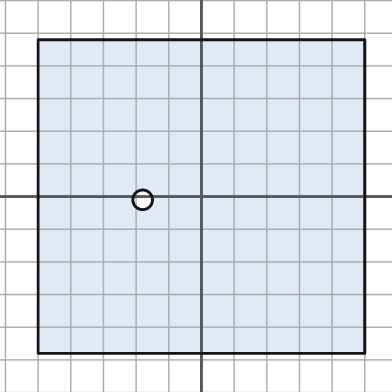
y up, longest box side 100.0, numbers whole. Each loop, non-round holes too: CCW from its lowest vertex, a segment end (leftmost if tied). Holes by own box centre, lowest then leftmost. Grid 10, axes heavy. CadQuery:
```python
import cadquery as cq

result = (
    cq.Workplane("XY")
    .moveTo(-50.0, -48.0)
    .lineTo(50.0, -48.0)
    .lineTo(50.0, 48.0)
    .lineTo(-50.0, 48.0)
    .close()
    .moveTo(-18.0, -1.0)
    .circle(3.0)
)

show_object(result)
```